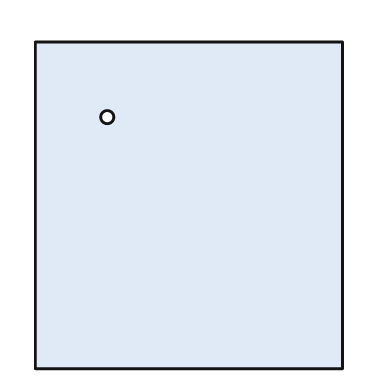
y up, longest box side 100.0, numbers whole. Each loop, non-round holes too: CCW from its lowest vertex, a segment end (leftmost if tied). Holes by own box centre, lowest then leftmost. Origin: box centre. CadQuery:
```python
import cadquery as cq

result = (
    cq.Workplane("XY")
    .moveTo(-47.0, -50.0)
    .lineTo(47.0, -50.0)
    .lineTo(47.0, 50.0)
    .lineTo(-47.0, 50.0)
    .close()
    .moveTo(-25.0, 27.0)
    .circle(2.0)
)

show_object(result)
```